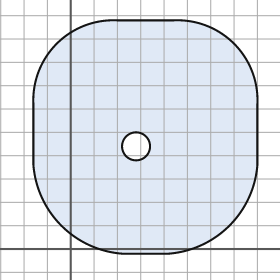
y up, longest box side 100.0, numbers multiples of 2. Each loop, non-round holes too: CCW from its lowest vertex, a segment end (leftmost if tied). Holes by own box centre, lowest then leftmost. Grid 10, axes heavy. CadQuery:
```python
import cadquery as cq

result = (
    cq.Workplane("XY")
    .moveTo(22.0, -2.0)
    .lineTo(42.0, -2.0)
    .threePointArc((68.0, 10.0), (80.0, 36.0))
    .lineTo(80.0, 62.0)
    .threePointArc((70.0, 88.0), (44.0, 98.0))
    .lineTo(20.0, 98.0)
    .threePointArc((-6.0, 88.0), (-16.0, 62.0))
    .lineTo(-16.0, 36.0)
    .threePointArc((-4.0, 10.0), (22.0, -2.0))
    .close()
    .moveTo(28.0, 44.0)
    .circle(6.0)
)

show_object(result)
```